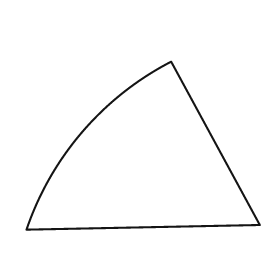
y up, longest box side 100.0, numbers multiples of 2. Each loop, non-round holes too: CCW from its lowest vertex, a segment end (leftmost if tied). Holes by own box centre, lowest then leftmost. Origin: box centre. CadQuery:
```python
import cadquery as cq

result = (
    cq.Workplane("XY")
    .moveTo(-50.0, -36.0)
    .lineTo(50.0, -34.0)
    .lineTo(12.0, 36.0)
    .threePointArc((-26.0, 6.0), (-50.0, -36.0))
    .close()
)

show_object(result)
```